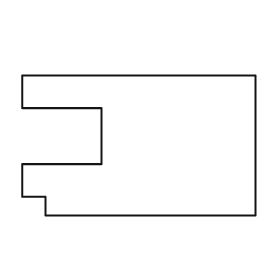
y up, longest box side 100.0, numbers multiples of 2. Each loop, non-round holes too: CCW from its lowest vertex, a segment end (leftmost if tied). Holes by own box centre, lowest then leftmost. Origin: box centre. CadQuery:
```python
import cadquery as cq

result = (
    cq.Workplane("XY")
    .moveTo(-40.0, -30.0)
    .lineTo(50.0, -30.0)
    .lineTo(50.0, 30.0)
    .lineTo(-50.0, 30.0)
    .lineTo(-50.0, 16.0)
    .lineTo(-16.0, 16.0)
    .lineTo(-16.0, -8.0)
    .lineTo(-50.0, -8.0)
    .lineTo(-50.0, -22.0)
    .lineTo(-40.0, -22.0)
    .close()
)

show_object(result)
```